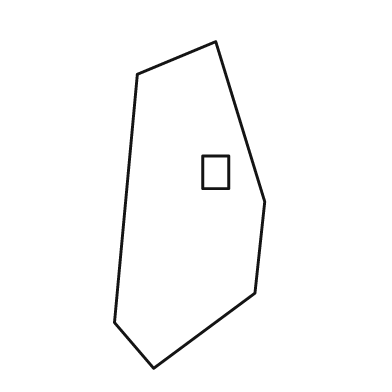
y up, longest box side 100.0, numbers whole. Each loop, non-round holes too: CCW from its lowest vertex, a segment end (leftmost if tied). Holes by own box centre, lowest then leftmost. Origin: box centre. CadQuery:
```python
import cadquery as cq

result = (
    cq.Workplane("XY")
    .moveTo(-11.0, -50.0)
    .lineTo(20.0, -27.0)
    .lineTo(23.0, 1.0)
    .lineTo(8.0, 50.0)
    .lineTo(-16.0, 40.0)
    .lineTo(-23.0, -36.0)
    .close()
    .moveTo(4.0, 5.0)
    .lineTo(12.0, 5.0)
    .lineTo(12.0, 15.0)
    .lineTo(4.0, 15.0)
    .close()
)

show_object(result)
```